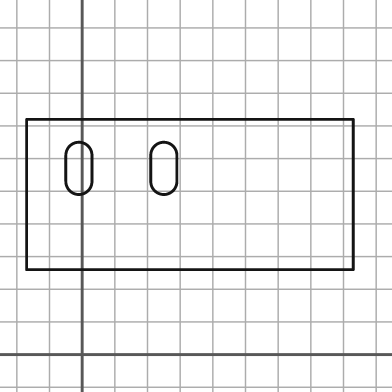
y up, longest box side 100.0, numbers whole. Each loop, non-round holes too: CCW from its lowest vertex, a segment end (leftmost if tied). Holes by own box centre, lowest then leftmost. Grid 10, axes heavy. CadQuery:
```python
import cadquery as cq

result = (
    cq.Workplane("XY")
    .moveTo(-17.0, 26.0)
    .lineTo(83.0, 26.0)
    .lineTo(83.0, 72.0)
    .lineTo(-17.0, 72.0)
    .close()
    .moveTo(-5.0, 53.0)
    .threePointArc((-1.0, 49.0), (3.0, 53.0))
    .lineTo(3.0, 61.0)
    .threePointArc((-1.0, 65.0), (-5.0, 61.0))
    .close()
    .moveTo(21.0, 53.0)
    .threePointArc((25.0, 49.0), (29.0, 53.0))
    .lineTo(29.0, 61.0)
    .threePointArc((25.0, 65.0), (21.0, 61.0))
    .close()
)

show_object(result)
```